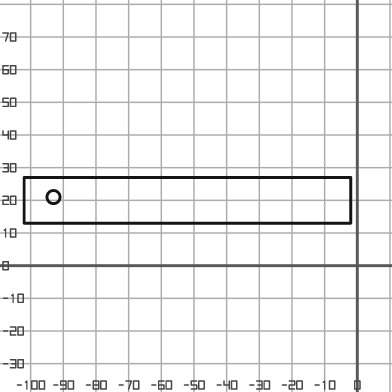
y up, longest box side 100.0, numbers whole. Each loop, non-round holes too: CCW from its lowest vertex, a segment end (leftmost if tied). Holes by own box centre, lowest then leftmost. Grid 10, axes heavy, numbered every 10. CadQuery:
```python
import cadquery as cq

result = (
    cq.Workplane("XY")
    .moveTo(-102.0, 13.0)
    .lineTo(-2.0, 13.0)
    .lineTo(-2.0, 27.0)
    .lineTo(-102.0, 27.0)
    .close()
    .moveTo(-93.0, 21.0)
    .circle(2.0)
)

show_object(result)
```